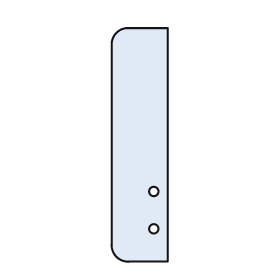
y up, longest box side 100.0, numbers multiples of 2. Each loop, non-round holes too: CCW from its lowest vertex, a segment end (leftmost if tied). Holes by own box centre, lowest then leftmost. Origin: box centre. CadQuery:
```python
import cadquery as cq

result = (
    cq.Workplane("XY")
    .moveTo(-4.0, -50.0)
    .lineTo(12.0, -50.0)
    .lineTo(12.0, 50.0)
    .lineTo(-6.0, 50.0)
    .threePointArc((-10.0, 48.0), (-12.0, 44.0))
    .lineTo(-12.0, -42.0)
    .threePointArc((-10.0, -48.0), (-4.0, -50.0))
    .close()
    .moveTo(6.0, -36.0)
    .circle(2.0)
    .moveTo(6.0, -20.0)
    .circle(2.0)
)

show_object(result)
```